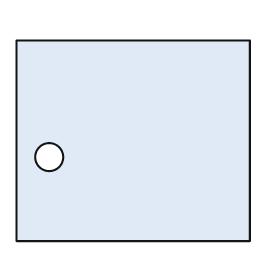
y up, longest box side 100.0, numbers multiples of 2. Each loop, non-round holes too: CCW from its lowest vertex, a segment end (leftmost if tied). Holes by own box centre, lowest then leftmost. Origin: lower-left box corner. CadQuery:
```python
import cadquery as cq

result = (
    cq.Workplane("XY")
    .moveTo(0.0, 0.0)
    .lineTo(100.0, 0.0)
    .lineTo(100.0, 86.0)
    .lineTo(0.0, 86.0)
    .close()
    .moveTo(14.0, 36.0)
    .circle(6.0)
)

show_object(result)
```